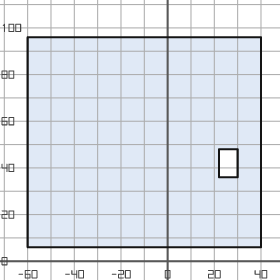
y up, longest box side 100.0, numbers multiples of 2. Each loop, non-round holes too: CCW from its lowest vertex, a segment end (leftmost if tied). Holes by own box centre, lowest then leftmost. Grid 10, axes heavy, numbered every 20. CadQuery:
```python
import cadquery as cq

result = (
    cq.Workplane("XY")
    .moveTo(-60.0, 6.0)
    .lineTo(40.0, 6.0)
    .lineTo(40.0, 96.0)
    .lineTo(-60.0, 96.0)
    .close()
    .moveTo(22.0, 36.0)
    .lineTo(30.0, 36.0)
    .lineTo(30.0, 48.0)
    .lineTo(22.0, 48.0)
    .close()
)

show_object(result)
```